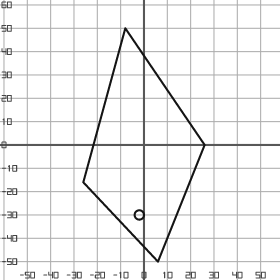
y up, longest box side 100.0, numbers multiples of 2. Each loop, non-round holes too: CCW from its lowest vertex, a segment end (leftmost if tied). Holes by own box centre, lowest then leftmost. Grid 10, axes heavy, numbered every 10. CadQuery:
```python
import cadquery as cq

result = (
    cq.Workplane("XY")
    .moveTo(6.0, -50.0)
    .lineTo(26.0, 0.0)
    .lineTo(-8.0, 50.0)
    .lineTo(-26.0, -16.0)
    .close()
    .moveTo(-2.0, -30.0)
    .circle(2.0)
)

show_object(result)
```